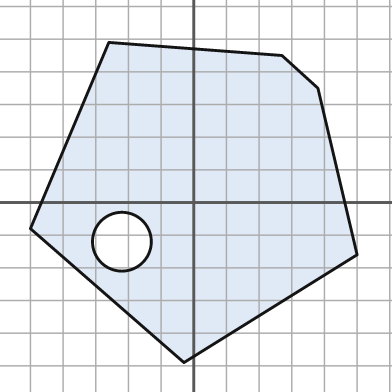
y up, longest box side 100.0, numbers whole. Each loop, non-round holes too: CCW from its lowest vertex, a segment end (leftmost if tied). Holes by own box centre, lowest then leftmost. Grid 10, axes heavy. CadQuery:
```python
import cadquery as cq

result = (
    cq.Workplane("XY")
    .moveTo(-3.0, -49.0)
    .lineTo(50.0, -16.0)
    .lineTo(38.0, 35.0)
    .lineTo(27.0, 45.0)
    .lineTo(-26.0, 49.0)
    .lineTo(-50.0, -8.0)
    .close()
    .moveTo(-22.0, -12.0)
    .circle(9.0)
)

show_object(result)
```